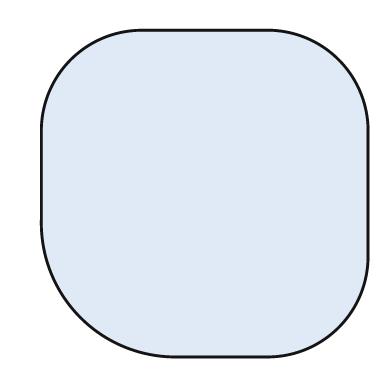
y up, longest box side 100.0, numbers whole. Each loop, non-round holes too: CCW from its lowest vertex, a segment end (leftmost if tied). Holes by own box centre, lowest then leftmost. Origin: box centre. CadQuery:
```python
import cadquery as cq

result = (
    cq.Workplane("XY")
    .moveTo(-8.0, -50.0)
    .lineTo(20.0, -50.0)
    .threePointArc((41.0, -41.0), (50.0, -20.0))
    .lineTo(50.0, 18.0)
    .threePointArc((41.0, 41.0), (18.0, 50.0))
    .lineTo(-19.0, 50.0)
    .threePointArc((-41.0, 41.0), (-50.0, 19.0))
    .lineTo(-50.0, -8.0)
    .threePointArc((-38.0, -38.0), (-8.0, -50.0))
    .close()
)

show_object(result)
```